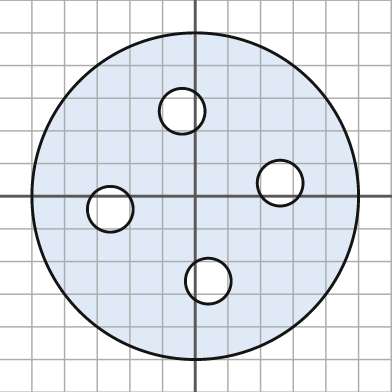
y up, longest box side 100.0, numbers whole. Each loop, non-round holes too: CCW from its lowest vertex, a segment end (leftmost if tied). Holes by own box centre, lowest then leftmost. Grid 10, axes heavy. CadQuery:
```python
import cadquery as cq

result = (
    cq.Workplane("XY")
    .moveTo(0.0, 0.0)
    .circle(50.0)
    .moveTo(4.0, -26.0)
    .circle(7.0)
    .moveTo(-26.0, -4.0)
    .circle(7.0)
    .moveTo(26.0, 4.0)
    .circle(7.0)
    .moveTo(-4.0, 26.0)
    .circle(7.0)
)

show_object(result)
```